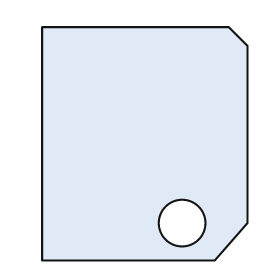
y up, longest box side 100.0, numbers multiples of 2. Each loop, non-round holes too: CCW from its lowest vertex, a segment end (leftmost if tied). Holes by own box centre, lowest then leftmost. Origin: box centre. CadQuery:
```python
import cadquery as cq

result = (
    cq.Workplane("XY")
    .moveTo(-44.0, -50.0)
    .lineTo(30.0, -50.0)
    .lineTo(44.0, -34.0)
    .lineTo(44.0, 42.0)
    .lineTo(36.0, 50.0)
    .lineTo(-44.0, 50.0)
    .close()
    .moveTo(16.0, -34.0)
    .circle(10.0)
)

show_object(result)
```